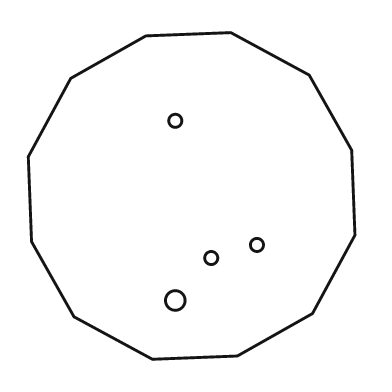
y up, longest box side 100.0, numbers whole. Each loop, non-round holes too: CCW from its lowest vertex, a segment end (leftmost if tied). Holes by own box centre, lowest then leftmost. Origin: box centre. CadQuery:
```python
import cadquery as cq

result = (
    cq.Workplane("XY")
    .moveTo(-12.0, -50.0)
    .lineTo(14.0, -49.0)
    .lineTo(37.0, -36.0)
    .lineTo(50.0, -12.0)
    .lineTo(49.0, 14.0)
    .lineTo(36.0, 37.0)
    .lineTo(12.0, 50.0)
    .lineTo(-14.0, 49.0)
    .lineTo(-37.0, 36.0)
    .lineTo(-50.0, 12.0)
    .lineTo(-49.0, -14.0)
    .lineTo(-36.0, -37.0)
    .close()
    .moveTo(-5.0, -32.0)
    .circle(3.0)
    .moveTo(6.0, -19.0)
    .circle(2.0)
    .moveTo(20.0, -15.0)
    .circle(2.0)
    .moveTo(-5.0, 23.0)
    .circle(2.0)
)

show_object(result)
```